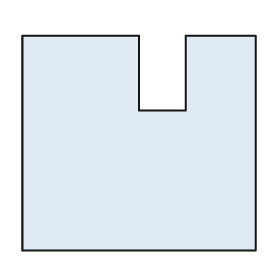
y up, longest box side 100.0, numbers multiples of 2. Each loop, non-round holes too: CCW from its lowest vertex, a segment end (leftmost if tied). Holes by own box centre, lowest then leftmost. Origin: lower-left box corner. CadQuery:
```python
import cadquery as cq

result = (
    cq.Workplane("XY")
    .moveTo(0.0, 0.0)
    .lineTo(100.0, 0.0)
    .lineTo(100.0, 92.0)
    .lineTo(70.0, 92.0)
    .lineTo(70.0, 60.0)
    .lineTo(50.0, 60.0)
    .lineTo(50.0, 92.0)
    .lineTo(0.0, 92.0)
    .close()
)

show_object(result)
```